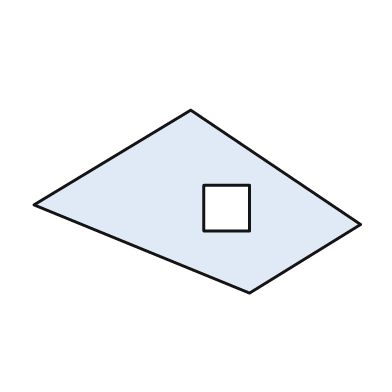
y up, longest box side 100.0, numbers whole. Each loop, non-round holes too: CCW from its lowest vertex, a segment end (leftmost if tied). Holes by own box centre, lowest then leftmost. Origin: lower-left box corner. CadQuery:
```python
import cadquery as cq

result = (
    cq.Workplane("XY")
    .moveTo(66.0, 0.0)
    .lineTo(100.0, 21.0)
    .lineTo(48.0, 56.0)
    .lineTo(0.0, 27.0)
    .close()
    .moveTo(52.0, 19.0)
    .lineTo(66.0, 19.0)
    .lineTo(66.0, 33.0)
    .lineTo(52.0, 33.0)
    .close()
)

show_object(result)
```